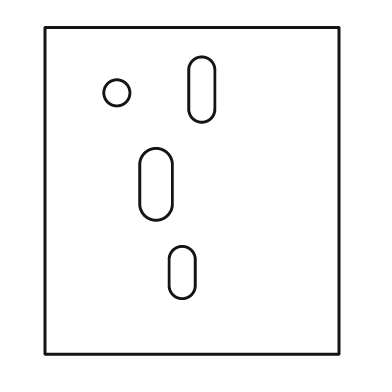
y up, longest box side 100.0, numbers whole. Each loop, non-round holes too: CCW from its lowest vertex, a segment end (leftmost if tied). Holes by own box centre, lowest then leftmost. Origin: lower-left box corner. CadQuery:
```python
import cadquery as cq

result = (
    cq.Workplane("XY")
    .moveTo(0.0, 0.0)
    .lineTo(90.0, 0.0)
    .lineTo(90.0, 100.0)
    .lineTo(0.0, 100.0)
    .close()
    .moveTo(38.0, 21.0)
    .threePointArc((42.0, 17.0), (46.0, 21.0))
    .lineTo(46.0, 29.0)
    .threePointArc((42.0, 33.0), (38.0, 29.0))
    .close()
    .moveTo(29.0, 46.0)
    .threePointArc((34.0, 41.0), (39.0, 46.0))
    .lineTo(39.0, 58.0)
    .threePointArc((34.0, 63.0), (29.0, 58.0))
    .close()
    .moveTo(22.0, 80.0)
    .circle(4.0)
    .moveTo(44.0, 75.0)
    .threePointArc((48.0, 71.0), (52.0, 75.0))
    .lineTo(52.0, 87.0)
    .threePointArc((48.0, 91.0), (44.0, 87.0))
    .close()
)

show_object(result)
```